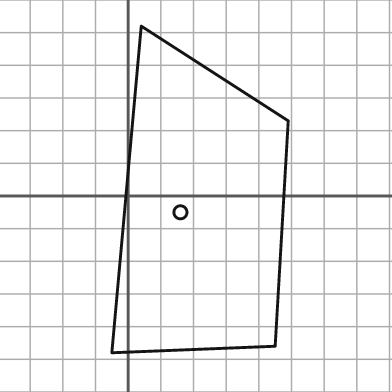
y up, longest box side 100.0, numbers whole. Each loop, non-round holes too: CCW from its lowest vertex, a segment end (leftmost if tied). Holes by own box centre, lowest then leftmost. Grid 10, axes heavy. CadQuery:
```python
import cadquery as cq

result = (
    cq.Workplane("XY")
    .moveTo(-5.0, -48.0)
    .lineTo(45.0, -46.0)
    .lineTo(49.0, 23.0)
    .lineTo(4.0, 52.0)
    .close()
    .moveTo(16.0, -5.0)
    .circle(2.0)
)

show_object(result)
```